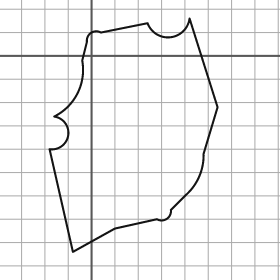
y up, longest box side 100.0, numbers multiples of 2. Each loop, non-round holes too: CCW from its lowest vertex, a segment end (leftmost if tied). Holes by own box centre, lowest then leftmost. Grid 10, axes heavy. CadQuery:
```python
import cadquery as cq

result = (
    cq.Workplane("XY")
    .moveTo(-8.0, -84.0)
    .lineTo(10.0, -74.0)
    .lineTo(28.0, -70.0)
    .threePointArc((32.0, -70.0), (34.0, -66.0))
    .lineTo(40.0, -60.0)
    .threePointArc((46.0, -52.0), (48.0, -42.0))
    .lineTo(54.0, -22.0)
    .lineTo(42.0, 16.0)
    .threePointArc((34.0, 8.0), (24.0, 14.0))
    .lineTo(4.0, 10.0)
    .threePointArc((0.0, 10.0), (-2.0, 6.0))
    .lineTo(-4.0, -2.0)
    .threePointArc((-6.0, -16.0), (-16.0, -26.0))
    .threePointArc((-10.0, -34.0), (-18.0, -40.0))
    .close()
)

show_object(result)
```